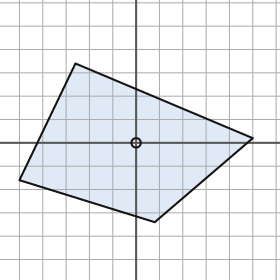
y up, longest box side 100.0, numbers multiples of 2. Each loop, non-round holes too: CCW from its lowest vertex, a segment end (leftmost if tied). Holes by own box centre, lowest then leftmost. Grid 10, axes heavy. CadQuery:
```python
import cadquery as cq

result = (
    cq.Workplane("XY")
    .moveTo(8.0, -34.0)
    .lineTo(50.0, 2.0)
    .lineTo(-26.0, 34.0)
    .lineTo(-50.0, -16.0)
    .close()
    .moveTo(0.0, 0.0)
    .circle(2.0)
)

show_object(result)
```